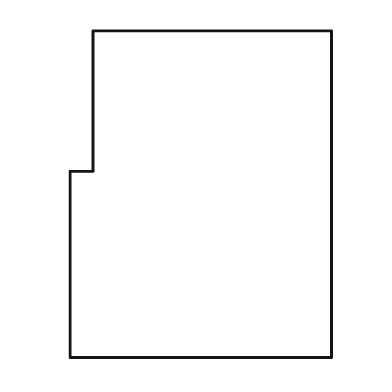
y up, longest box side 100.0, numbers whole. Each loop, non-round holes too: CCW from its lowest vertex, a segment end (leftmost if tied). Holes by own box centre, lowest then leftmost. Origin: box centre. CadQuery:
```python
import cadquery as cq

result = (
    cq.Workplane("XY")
    .moveTo(-40.0, -50.0)
    .lineTo(40.0, -50.0)
    .lineTo(40.0, 50.0)
    .lineTo(-33.0, 50.0)
    .lineTo(-33.0, 7.0)
    .lineTo(-40.0, 7.0)
    .close()
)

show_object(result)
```